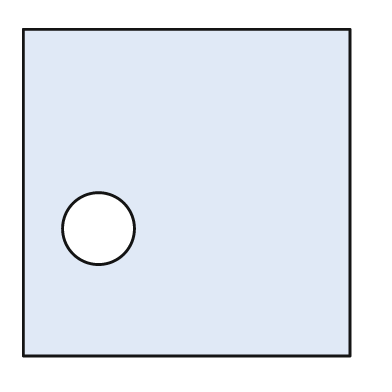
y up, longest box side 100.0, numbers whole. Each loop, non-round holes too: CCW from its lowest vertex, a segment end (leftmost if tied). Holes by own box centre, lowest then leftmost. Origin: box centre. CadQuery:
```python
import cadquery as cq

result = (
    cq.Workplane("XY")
    .moveTo(-50.0, -50.0)
    .lineTo(50.0, -50.0)
    .lineTo(50.0, 50.0)
    .lineTo(-50.0, 50.0)
    .close()
    .moveTo(-27.0, -11.0)
    .circle(11.0)
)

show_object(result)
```